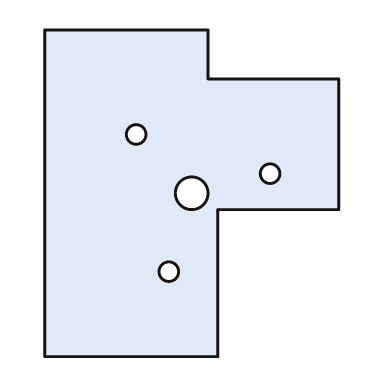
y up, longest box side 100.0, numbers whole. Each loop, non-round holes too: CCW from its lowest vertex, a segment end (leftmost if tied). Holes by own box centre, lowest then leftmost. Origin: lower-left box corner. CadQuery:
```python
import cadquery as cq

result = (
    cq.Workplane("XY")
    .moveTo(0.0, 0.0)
    .lineTo(53.0, 0.0)
    .lineTo(53.0, 45.0)
    .lineTo(90.0, 45.0)
    .lineTo(90.0, 85.0)
    .lineTo(50.0, 85.0)
    .lineTo(50.0, 100.0)
    .lineTo(0.0, 100.0)
    .close()
    .moveTo(38.0, 26.0)
    .circle(3.0)
    .moveTo(45.0, 50.0)
    .circle(5.0)
    .moveTo(69.0, 56.0)
    .circle(3.0)
    .moveTo(28.0, 68.0)
    .circle(3.0)
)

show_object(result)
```